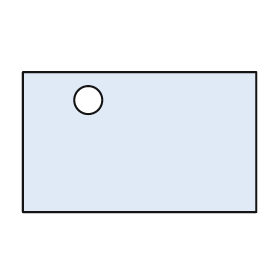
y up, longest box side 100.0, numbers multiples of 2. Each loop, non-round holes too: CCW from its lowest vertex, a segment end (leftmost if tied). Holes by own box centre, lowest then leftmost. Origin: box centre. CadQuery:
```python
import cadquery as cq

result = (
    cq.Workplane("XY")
    .moveTo(-50.0, -30.0)
    .lineTo(50.0, -30.0)
    .lineTo(50.0, 30.0)
    .lineTo(-50.0, 30.0)
    .close()
    .moveTo(-22.0, 18.0)
    .circle(6.0)
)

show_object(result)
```